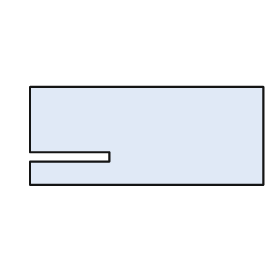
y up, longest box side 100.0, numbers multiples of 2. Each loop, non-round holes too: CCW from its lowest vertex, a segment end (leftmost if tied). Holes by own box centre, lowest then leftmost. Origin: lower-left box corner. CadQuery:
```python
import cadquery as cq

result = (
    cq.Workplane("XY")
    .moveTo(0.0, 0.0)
    .lineTo(100.0, 0.0)
    .lineTo(100.0, 42.0)
    .lineTo(0.0, 42.0)
    .lineTo(0.0, 14.0)
    .lineTo(34.0, 14.0)
    .lineTo(34.0, 10.0)
    .lineTo(0.0, 10.0)
    .close()
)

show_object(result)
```